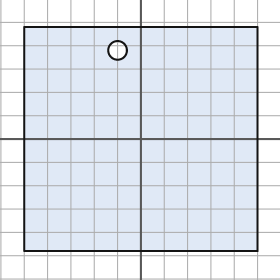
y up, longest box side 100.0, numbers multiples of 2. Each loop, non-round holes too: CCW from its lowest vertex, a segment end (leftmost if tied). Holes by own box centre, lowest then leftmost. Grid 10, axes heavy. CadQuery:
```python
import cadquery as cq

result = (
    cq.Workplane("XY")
    .moveTo(-50.0, -48.0)
    .lineTo(50.0, -48.0)
    .lineTo(50.0, 48.0)
    .lineTo(-50.0, 48.0)
    .close()
    .moveTo(-10.0, 38.0)
    .circle(4.0)
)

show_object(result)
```